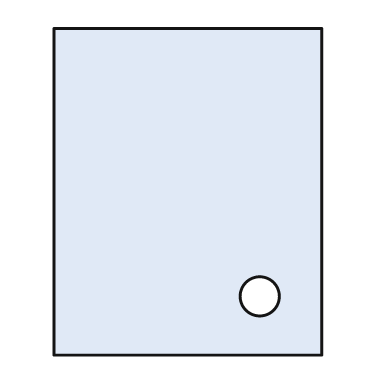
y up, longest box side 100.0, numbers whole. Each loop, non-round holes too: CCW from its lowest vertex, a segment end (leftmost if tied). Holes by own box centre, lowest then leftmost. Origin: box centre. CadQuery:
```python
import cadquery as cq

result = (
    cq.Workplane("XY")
    .moveTo(-41.0, -50.0)
    .lineTo(41.0, -50.0)
    .lineTo(41.0, 50.0)
    .lineTo(-41.0, 50.0)
    .close()
    .moveTo(22.0, -32.0)
    .circle(6.0)
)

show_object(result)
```